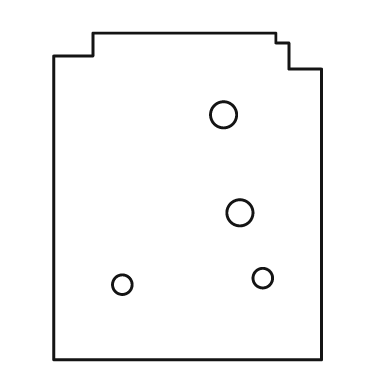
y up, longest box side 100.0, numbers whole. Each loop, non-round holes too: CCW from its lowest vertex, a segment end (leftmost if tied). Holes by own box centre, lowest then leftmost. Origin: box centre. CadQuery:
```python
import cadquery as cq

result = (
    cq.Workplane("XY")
    .moveTo(-41.0, -50.0)
    .lineTo(41.0, -50.0)
    .lineTo(41.0, 39.0)
    .lineTo(31.0, 39.0)
    .lineTo(31.0, 47.0)
    .lineTo(27.0, 47.0)
    .lineTo(27.0, 50.0)
    .lineTo(-29.0, 50.0)
    .lineTo(-29.0, 43.0)
    .lineTo(-41.0, 43.0)
    .close()
    .moveTo(-20.0, -27.0)
    .circle(3.0)
    .moveTo(23.0, -25.0)
    .circle(3.0)
    .moveTo(16.0, -5.0)
    .circle(4.0)
    .moveTo(11.0, 25.0)
    .circle(4.0)
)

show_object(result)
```